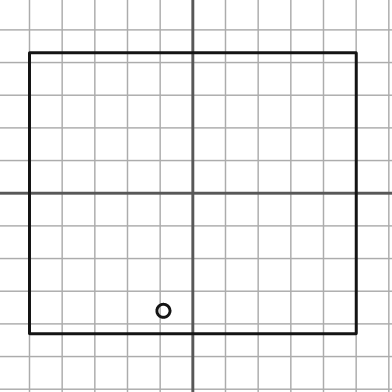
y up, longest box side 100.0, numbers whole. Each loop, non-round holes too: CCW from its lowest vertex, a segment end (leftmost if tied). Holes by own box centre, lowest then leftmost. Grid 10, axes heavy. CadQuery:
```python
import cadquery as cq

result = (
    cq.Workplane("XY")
    .moveTo(-50.0, -43.0)
    .lineTo(50.0, -43.0)
    .lineTo(50.0, 43.0)
    .lineTo(-50.0, 43.0)
    .close()
    .moveTo(-9.0, -36.0)
    .circle(2.0)
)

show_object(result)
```